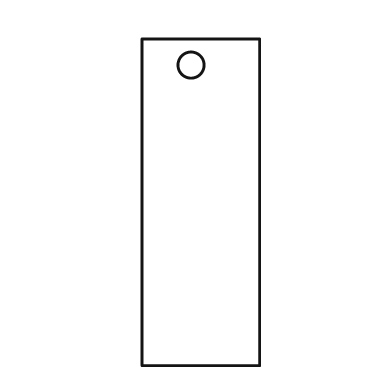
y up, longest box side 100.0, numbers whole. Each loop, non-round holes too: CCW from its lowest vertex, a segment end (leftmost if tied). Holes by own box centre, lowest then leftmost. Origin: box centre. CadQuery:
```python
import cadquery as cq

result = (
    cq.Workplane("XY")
    .moveTo(-18.0, -50.0)
    .lineTo(18.0, -50.0)
    .lineTo(18.0, 50.0)
    .lineTo(-18.0, 50.0)
    .close()
    .moveTo(-3.0, 42.0)
    .circle(4.0)
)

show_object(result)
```